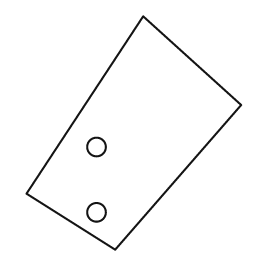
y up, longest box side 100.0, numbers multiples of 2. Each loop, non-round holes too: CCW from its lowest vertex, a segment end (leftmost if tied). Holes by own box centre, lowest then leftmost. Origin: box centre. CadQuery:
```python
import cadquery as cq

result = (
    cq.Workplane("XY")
    .moveTo(-8.0, -50.0)
    .lineTo(46.0, 12.0)
    .lineTo(4.0, 50.0)
    .lineTo(-46.0, -26.0)
    .close()
    .moveTo(-16.0, -34.0)
    .circle(4.0)
    .moveTo(-16.0, -6.0)
    .circle(4.0)
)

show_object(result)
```